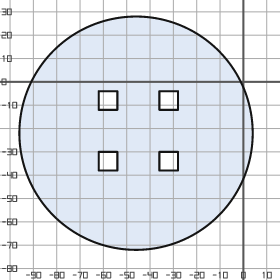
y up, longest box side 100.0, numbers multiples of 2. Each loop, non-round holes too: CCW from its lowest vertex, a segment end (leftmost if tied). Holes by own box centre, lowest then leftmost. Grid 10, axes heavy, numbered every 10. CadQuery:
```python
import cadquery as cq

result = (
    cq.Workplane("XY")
    .moveTo(-46.0, -22.0)
    .circle(50.0)
    .moveTo(-62.0, -38.0)
    .lineTo(-54.0, -38.0)
    .lineTo(-54.0, -30.0)
    .lineTo(-62.0, -30.0)
    .close()
    .moveTo(-36.0, -38.0)
    .lineTo(-28.0, -38.0)
    .lineTo(-28.0, -30.0)
    .lineTo(-36.0, -30.0)
    .close()
    .moveTo(-62.0, -12.0)
    .lineTo(-54.0, -12.0)
    .lineTo(-54.0, -4.0)
    .lineTo(-62.0, -4.0)
    .close()
    .moveTo(-36.0, -12.0)
    .lineTo(-28.0, -12.0)
    .lineTo(-28.0, -4.0)
    .lineTo(-36.0, -4.0)
    .close()
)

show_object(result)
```